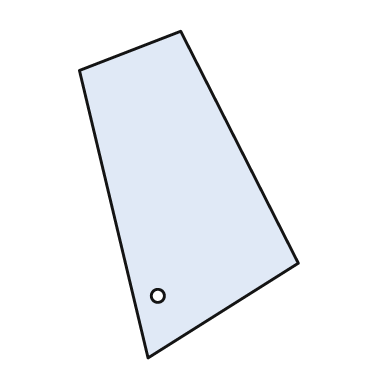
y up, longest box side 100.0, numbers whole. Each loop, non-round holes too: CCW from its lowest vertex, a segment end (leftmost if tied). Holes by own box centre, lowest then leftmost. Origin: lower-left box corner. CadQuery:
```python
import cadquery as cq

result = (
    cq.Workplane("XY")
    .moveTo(21.0, 0.0)
    .lineTo(67.0, 29.0)
    .lineTo(31.0, 100.0)
    .lineTo(0.0, 88.0)
    .close()
    .moveTo(24.0, 19.0)
    .circle(2.0)
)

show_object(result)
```